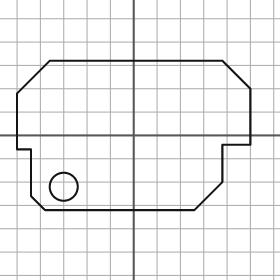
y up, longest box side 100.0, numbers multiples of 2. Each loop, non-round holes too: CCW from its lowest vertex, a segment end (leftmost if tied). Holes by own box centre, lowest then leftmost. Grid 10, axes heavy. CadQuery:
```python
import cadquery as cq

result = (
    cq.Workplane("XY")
    .moveTo(-38.0, -32.0)
    .lineTo(26.0, -32.0)
    .lineTo(38.0, -20.0)
    .lineTo(38.0, -4.0)
    .lineTo(50.0, -4.0)
    .lineTo(50.0, 20.0)
    .lineTo(38.0, 32.0)
    .lineTo(-36.0, 32.0)
    .lineTo(-50.0, 18.0)
    .lineTo(-50.0, -6.0)
    .lineTo(-44.0, -6.0)
    .lineTo(-44.0, -26.0)
    .close()
    .moveTo(-30.0, -22.0)
    .circle(6.0)
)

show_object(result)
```